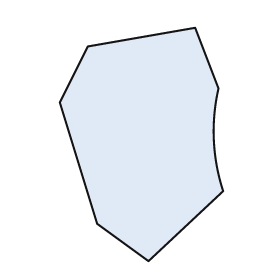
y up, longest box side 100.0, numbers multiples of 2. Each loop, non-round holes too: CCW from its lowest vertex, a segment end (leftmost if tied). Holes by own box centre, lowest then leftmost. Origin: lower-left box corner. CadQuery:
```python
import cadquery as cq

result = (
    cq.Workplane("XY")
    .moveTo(38.0, 0.0)
    .lineTo(70.0, 30.0)
    .threePointArc((66.0, 52.0), (68.0, 74.0))
    .lineTo(58.0, 100.0)
    .lineTo(12.0, 92.0)
    .lineTo(0.0, 68.0)
    .lineTo(16.0, 16.0)
    .close()
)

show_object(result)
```